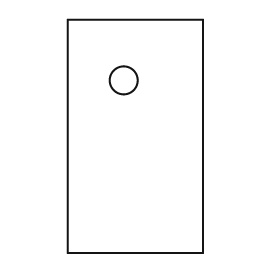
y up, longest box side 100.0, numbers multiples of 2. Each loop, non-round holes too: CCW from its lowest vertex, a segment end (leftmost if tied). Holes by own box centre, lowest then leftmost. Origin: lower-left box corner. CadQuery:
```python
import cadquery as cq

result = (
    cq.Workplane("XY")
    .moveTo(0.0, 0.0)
    .lineTo(58.0, 0.0)
    .lineTo(58.0, 100.0)
    .lineTo(0.0, 100.0)
    .close()
    .moveTo(24.0, 74.0)
    .circle(6.0)
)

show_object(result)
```